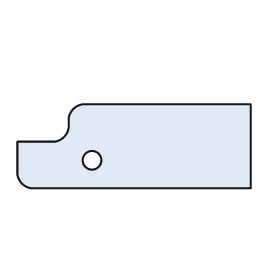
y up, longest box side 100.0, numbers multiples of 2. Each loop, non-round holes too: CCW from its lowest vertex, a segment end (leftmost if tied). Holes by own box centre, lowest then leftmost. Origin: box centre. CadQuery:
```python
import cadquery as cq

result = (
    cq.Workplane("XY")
    .moveTo(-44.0, -18.0)
    .lineTo(50.0, -18.0)
    .lineTo(50.0, 18.0)
    .lineTo(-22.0, 18.0)
    .threePointArc((-26.0, 16.0), (-28.0, 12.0))
    .lineTo(-28.0, 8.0)
    .threePointArc((-30.0, 4.0), (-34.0, 2.0))
    .lineTo(-50.0, 2.0)
    .lineTo(-50.0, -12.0)
    .threePointArc((-48.0, -16.0), (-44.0, -18.0))
    .close()
    .moveTo(-18.0, -6.0)
    .circle(4.0)
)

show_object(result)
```